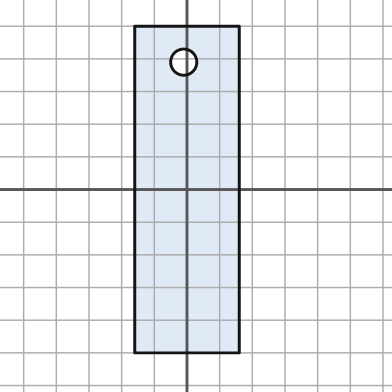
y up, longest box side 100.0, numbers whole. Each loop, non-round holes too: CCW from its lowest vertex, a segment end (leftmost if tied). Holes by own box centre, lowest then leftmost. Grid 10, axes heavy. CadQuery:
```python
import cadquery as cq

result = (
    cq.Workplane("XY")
    .moveTo(-16.0, -50.0)
    .lineTo(16.0, -50.0)
    .lineTo(16.0, 50.0)
    .lineTo(-16.0, 50.0)
    .close()
    .moveTo(-1.0, 39.0)
    .circle(4.0)
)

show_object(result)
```